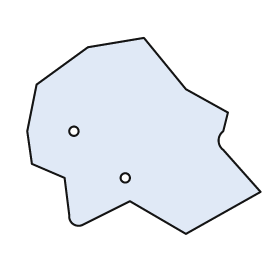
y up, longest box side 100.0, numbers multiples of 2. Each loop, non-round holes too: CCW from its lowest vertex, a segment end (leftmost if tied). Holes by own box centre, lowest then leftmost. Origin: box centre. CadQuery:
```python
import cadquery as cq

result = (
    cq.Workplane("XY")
    .moveTo(18.0, -42.0)
    .lineTo(50.0, -24.0)
    .lineTo(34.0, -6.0)
    .threePointArc((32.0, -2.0), (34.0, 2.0))
    .lineTo(36.0, 10.0)
    .lineTo(18.0, 20.0)
    .lineTo(0.0, 42.0)
    .lineTo(-24.0, 38.0)
    .lineTo(-46.0, 22.0)
    .lineTo(-50.0, 2.0)
    .lineTo(-48.0, -12.0)
    .lineTo(-34.0, -18.0)
    .lineTo(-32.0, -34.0)
    .threePointArc((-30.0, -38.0), (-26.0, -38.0))
    .lineTo(-6.0, -28.0)
    .close()
    .moveTo(-8.0, -18.0)
    .circle(2.0)
    .moveTo(-30.0, 2.0)
    .circle(2.0)
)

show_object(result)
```